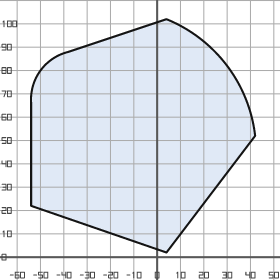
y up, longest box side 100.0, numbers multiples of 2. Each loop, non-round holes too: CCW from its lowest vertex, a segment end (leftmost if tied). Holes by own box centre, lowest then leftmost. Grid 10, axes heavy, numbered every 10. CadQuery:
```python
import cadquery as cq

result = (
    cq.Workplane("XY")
    .moveTo(4.0, 2.0)
    .lineTo(42.0, 52.0)
    .threePointArc((30.0, 82.0), (4.0, 102.0))
    .lineTo(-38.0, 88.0)
    .threePointArc((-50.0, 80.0), (-54.0, 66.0))
    .lineTo(-54.0, 22.0)
    .close()
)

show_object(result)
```